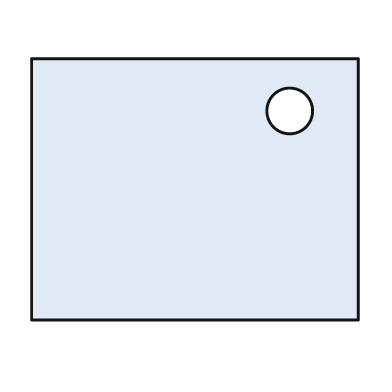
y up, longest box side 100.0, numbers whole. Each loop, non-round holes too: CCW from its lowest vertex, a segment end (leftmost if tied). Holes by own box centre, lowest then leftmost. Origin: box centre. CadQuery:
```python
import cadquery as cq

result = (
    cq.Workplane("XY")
    .moveTo(-50.0, -40.0)
    .lineTo(50.0, -40.0)
    .lineTo(50.0, 40.0)
    .lineTo(-50.0, 40.0)
    .close()
    .moveTo(29.0, 24.0)
    .circle(7.0)
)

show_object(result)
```